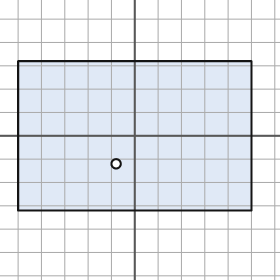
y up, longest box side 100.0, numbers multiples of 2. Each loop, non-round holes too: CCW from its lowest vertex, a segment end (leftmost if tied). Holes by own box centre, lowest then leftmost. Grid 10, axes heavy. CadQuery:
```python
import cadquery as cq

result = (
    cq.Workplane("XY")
    .moveTo(-50.0, -32.0)
    .lineTo(50.0, -32.0)
    .lineTo(50.0, 32.0)
    .lineTo(-50.0, 32.0)
    .close()
    .moveTo(-8.0, -12.0)
    .circle(2.0)
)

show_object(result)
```